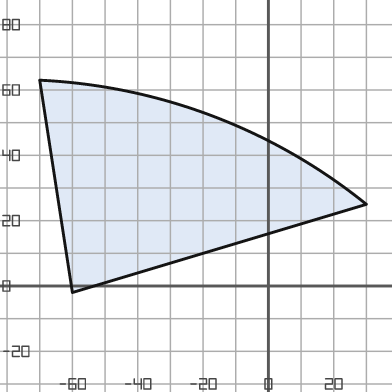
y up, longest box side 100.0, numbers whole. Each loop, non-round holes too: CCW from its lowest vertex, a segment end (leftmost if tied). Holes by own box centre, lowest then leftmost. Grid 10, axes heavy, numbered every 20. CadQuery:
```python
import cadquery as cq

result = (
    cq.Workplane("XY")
    .moveTo(-60.0, -2.0)
    .lineTo(30.0, 25.0)
    .threePointArc((-17.0, 52.0), (-70.0, 63.0))
    .close()
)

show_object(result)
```